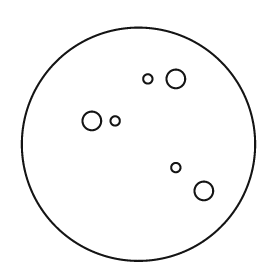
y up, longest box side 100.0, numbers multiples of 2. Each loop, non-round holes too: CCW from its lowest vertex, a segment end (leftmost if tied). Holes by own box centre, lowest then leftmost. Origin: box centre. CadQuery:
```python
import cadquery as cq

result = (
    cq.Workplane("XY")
    .moveTo(0.0, 0.0)
    .circle(50.0)
    .moveTo(28.0, -20.0)
    .circle(4.0)
    .moveTo(16.0, -10.0)
    .circle(2.0)
    .moveTo(-20.0, 10.0)
    .circle(4.0)
    .moveTo(-10.0, 10.0)
    .circle(2.0)
    .moveTo(4.0, 28.0)
    .circle(2.0)
    .moveTo(16.0, 28.0)
    .circle(4.0)
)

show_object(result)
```